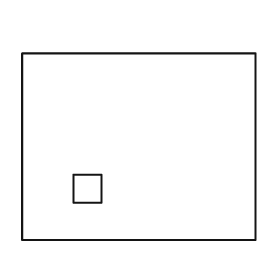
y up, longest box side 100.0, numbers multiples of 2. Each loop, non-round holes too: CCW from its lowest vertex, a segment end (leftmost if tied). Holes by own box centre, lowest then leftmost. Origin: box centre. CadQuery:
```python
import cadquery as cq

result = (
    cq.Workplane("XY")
    .moveTo(-50.0, -40.0)
    .lineTo(50.0, -40.0)
    .lineTo(50.0, 40.0)
    .lineTo(-50.0, 40.0)
    .close()
    .moveTo(-28.0, -24.0)
    .lineTo(-16.0, -24.0)
    .lineTo(-16.0, -12.0)
    .lineTo(-28.0, -12.0)
    .close()
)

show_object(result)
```